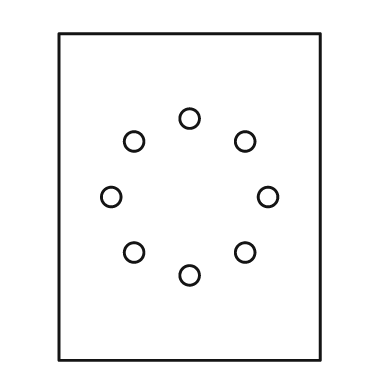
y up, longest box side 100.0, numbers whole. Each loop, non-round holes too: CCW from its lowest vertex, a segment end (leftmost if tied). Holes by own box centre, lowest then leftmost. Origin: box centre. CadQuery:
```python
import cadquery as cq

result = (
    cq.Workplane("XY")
    .moveTo(-40.0, -50.0)
    .lineTo(40.0, -50.0)
    .lineTo(40.0, 50.0)
    .lineTo(-40.0, 50.0)
    .close()
    .moveTo(0.0, -24.0)
    .circle(3.0)
    .moveTo(-17.0, -17.0)
    .circle(3.0)
    .moveTo(17.0, -17.0)
    .circle(3.0)
    .moveTo(-24.0, 0.0)
    .circle(3.0)
    .moveTo(24.0, 0.0)
    .circle(3.0)
    .moveTo(-17.0, 17.0)
    .circle(3.0)
    .moveTo(17.0, 17.0)
    .circle(3.0)
    .moveTo(0.0, 24.0)
    .circle(3.0)
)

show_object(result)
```